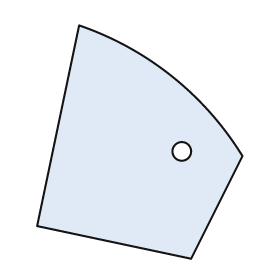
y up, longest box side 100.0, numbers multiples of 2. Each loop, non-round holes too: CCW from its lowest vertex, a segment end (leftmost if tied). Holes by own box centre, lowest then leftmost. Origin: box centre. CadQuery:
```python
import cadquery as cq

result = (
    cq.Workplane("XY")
    .moveTo(22.0, -50.0)
    .lineTo(44.0, -6.0)
    .threePointArc((14.0, 28.0), (-26.0, 50.0))
    .lineTo(-44.0, -36.0)
    .close()
    .moveTo(18.0, -4.0)
    .circle(4.0)
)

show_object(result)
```